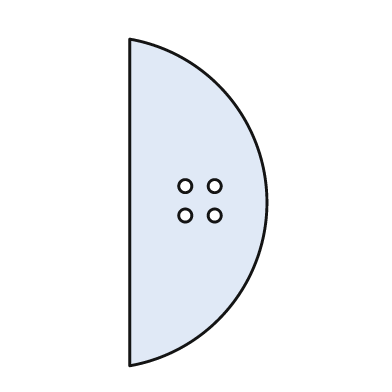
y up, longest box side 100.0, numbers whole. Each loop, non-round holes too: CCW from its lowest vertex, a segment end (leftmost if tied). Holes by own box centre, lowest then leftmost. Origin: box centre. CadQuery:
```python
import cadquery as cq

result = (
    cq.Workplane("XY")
    .moveTo(-21.0, -50.0)
    .threePointArc((21.0, 0.0), (-21.0, 50.0))
    .close()
    .moveTo(-4.0, -4.0)
    .circle(2.0)
    .moveTo(5.0, -4.0)
    .circle(2.0)
    .moveTo(-4.0, 5.0)
    .circle(2.0)
    .moveTo(5.0, 5.0)
    .circle(2.0)
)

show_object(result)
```